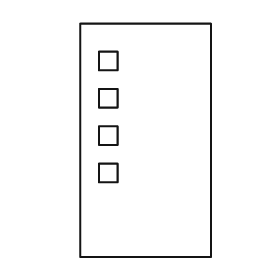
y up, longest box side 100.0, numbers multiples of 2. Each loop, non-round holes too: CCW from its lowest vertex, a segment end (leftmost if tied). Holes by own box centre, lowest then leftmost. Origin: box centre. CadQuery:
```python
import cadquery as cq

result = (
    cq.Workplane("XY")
    .moveTo(-28.0, -50.0)
    .lineTo(28.0, -50.0)
    .lineTo(28.0, 50.0)
    .lineTo(-28.0, 50.0)
    .close()
    .moveTo(-20.0, -18.0)
    .lineTo(-12.0, -18.0)
    .lineTo(-12.0, -10.0)
    .lineTo(-20.0, -10.0)
    .close()
    .moveTo(-20.0, -2.0)
    .lineTo(-12.0, -2.0)
    .lineTo(-12.0, 6.0)
    .lineTo(-20.0, 6.0)
    .close()
    .moveTo(-20.0, 14.0)
    .lineTo(-12.0, 14.0)
    .lineTo(-12.0, 22.0)
    .lineTo(-20.0, 22.0)
    .close()
    .moveTo(-20.0, 30.0)
    .lineTo(-12.0, 30.0)
    .lineTo(-12.0, 38.0)
    .lineTo(-20.0, 38.0)
    .close()
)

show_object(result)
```